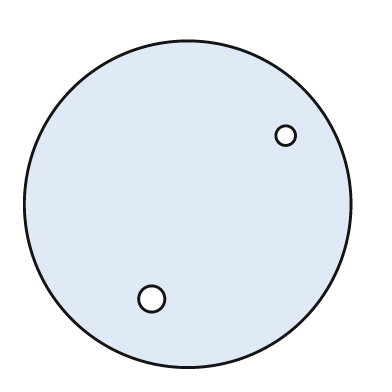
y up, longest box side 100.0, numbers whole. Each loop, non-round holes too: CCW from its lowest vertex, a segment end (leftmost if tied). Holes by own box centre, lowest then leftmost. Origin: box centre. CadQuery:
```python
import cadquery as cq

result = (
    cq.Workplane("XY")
    .moveTo(0.0, 0.0)
    .circle(50.0)
    .moveTo(-11.0, -29.0)
    .circle(4.0)
    .moveTo(30.0, 21.0)
    .circle(3.0)
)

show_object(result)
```